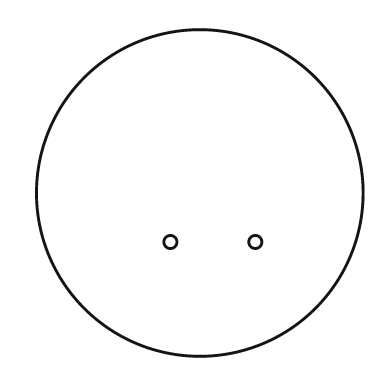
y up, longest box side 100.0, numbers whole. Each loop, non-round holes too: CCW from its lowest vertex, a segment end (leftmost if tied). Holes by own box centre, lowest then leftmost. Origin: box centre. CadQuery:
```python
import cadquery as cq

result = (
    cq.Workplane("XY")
    .moveTo(0.0, 0.0)
    .circle(50.0)
    .moveTo(-9.0, -15.0)
    .circle(2.0)
    .moveTo(17.0, -15.0)
    .circle(2.0)
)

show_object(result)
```